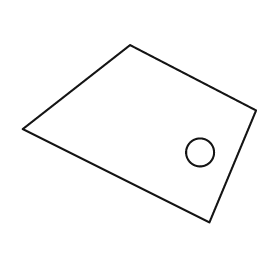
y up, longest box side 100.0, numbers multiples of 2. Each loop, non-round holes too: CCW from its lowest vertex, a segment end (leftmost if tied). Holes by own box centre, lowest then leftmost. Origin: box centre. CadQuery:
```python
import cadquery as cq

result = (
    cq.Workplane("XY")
    .moveTo(30.0, -38.0)
    .lineTo(50.0, 10.0)
    .lineTo(-4.0, 38.0)
    .lineTo(-50.0, 2.0)
    .close()
    .moveTo(26.0, -8.0)
    .circle(6.0)
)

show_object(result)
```